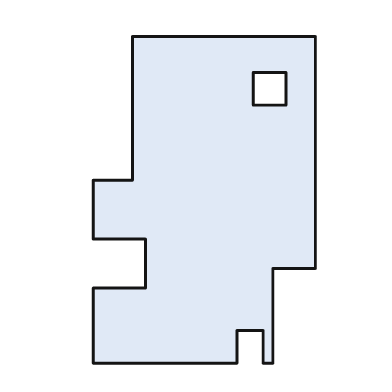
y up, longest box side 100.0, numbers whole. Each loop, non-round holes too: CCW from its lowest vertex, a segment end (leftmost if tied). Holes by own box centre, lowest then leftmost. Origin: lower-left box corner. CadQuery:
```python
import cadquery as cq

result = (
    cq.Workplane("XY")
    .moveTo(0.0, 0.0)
    .lineTo(44.0, 0.0)
    .lineTo(44.0, 10.0)
    .lineTo(52.0, 10.0)
    .lineTo(52.0, 0.0)
    .lineTo(55.0, 0.0)
    .lineTo(55.0, 29.0)
    .lineTo(68.0, 29.0)
    .lineTo(68.0, 100.0)
    .lineTo(12.0, 100.0)
    .lineTo(12.0, 56.0)
    .lineTo(0.0, 56.0)
    .lineTo(0.0, 38.0)
    .lineTo(16.0, 38.0)
    .lineTo(16.0, 23.0)
    .lineTo(0.0, 23.0)
    .close()
    .moveTo(49.0, 79.0)
    .lineTo(59.0, 79.0)
    .lineTo(59.0, 89.0)
    .lineTo(49.0, 89.0)
    .close()
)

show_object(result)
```